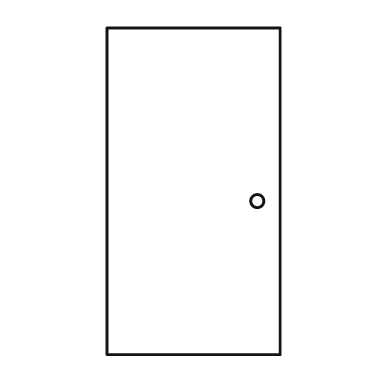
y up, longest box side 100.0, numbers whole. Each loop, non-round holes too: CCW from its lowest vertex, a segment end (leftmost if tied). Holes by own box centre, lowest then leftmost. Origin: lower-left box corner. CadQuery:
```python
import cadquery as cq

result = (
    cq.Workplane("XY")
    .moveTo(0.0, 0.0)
    .lineTo(53.0, 0.0)
    .lineTo(53.0, 100.0)
    .lineTo(0.0, 100.0)
    .close()
    .moveTo(46.0, 47.0)
    .circle(2.0)
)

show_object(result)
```